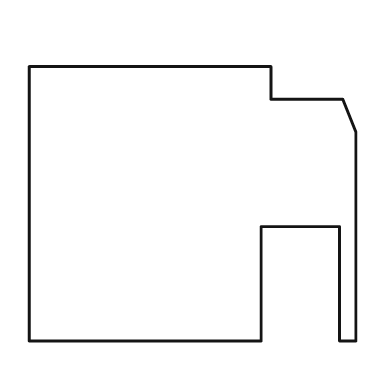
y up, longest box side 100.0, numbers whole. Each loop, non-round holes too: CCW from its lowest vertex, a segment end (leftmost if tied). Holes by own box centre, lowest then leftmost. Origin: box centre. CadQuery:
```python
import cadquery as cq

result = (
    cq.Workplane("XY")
    .moveTo(-50.0, -42.0)
    .lineTo(21.0, -42.0)
    .lineTo(21.0, -7.0)
    .lineTo(45.0, -7.0)
    .lineTo(45.0, -42.0)
    .lineTo(50.0, -42.0)
    .lineTo(50.0, 22.0)
    .lineTo(46.0, 32.0)
    .lineTo(24.0, 32.0)
    .lineTo(24.0, 42.0)
    .lineTo(-50.0, 42.0)
    .close()
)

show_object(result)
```